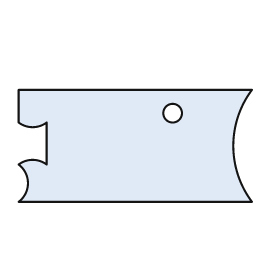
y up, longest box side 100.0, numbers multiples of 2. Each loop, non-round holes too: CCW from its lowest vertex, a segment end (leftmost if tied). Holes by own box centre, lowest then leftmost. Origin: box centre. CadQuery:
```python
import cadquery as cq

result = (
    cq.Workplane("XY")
    .moveTo(-50.0, -24.0)
    .lineTo(50.0, -24.0)
    .threePointArc((42.0, 0.0), (50.0, 24.0))
    .lineTo(-50.0, 24.0)
    .lineTo(-50.0, 10.0)
    .threePointArc((-44.0, 8.0), (-38.0, 10.0))
    .lineTo(-38.0, -8.0)
    .threePointArc((-44.0, -6.0), (-50.0, -8.0))
    .threePointArc((-46.0, -16.0), (-50.0, -24.0))
    .close()
    .moveTo(16.0, 14.0)
    .circle(4.0)
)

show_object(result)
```